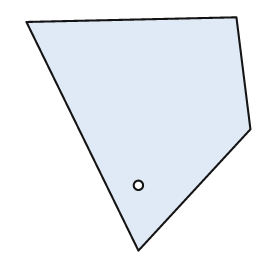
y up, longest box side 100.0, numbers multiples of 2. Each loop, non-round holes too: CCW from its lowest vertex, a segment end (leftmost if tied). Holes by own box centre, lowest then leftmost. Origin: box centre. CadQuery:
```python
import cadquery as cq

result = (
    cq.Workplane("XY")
    .moveTo(0.0, -50.0)
    .lineTo(48.0, 2.0)
    .lineTo(42.0, 50.0)
    .lineTo(-48.0, 48.0)
    .close()
    .moveTo(0.0, -22.0)
    .circle(2.0)
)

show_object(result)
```